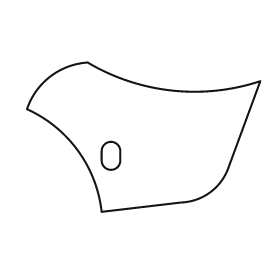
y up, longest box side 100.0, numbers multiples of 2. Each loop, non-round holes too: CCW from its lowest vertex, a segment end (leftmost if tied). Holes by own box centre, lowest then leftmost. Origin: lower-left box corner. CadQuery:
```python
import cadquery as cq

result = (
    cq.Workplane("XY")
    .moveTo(32.0, 0.0)
    .lineTo(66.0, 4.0)
    .threePointArc((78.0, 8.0), (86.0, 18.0))
    .lineTo(100.0, 56.0)
    .threePointArc((62.0, 52.0), (26.0, 64.0))
    .threePointArc((10.0, 58.0), (0.0, 44.0))
    .threePointArc((22.0, 26.0), (32.0, 0.0))
    .close()
    .moveTo(32.0, 22.0)
    .threePointArc((36.0, 18.0), (40.0, 22.0))
    .lineTo(40.0, 26.0)
    .threePointArc((36.0, 30.0), (32.0, 26.0))
    .close()
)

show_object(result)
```